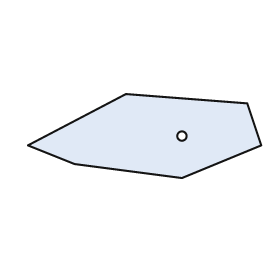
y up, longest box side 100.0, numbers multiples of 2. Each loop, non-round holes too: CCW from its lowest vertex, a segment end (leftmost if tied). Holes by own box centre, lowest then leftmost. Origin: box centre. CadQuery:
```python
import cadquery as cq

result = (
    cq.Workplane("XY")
    .moveTo(16.0, -18.0)
    .lineTo(50.0, -4.0)
    .lineTo(44.0, 14.0)
    .lineTo(-8.0, 18.0)
    .lineTo(-50.0, -4.0)
    .lineTo(-30.0, -12.0)
    .close()
    .moveTo(16.0, 0.0)
    .circle(2.0)
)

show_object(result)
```